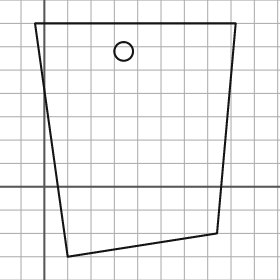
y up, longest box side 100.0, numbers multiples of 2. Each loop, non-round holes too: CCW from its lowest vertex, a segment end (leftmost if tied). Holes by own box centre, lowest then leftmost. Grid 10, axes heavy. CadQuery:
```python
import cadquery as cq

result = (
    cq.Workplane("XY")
    .moveTo(10.0, -30.0)
    .lineTo(74.0, -20.0)
    .lineTo(82.0, 70.0)
    .lineTo(-4.0, 70.0)
    .close()
    .moveTo(34.0, 58.0)
    .circle(4.0)
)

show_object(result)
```